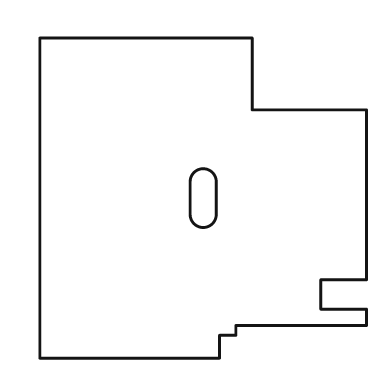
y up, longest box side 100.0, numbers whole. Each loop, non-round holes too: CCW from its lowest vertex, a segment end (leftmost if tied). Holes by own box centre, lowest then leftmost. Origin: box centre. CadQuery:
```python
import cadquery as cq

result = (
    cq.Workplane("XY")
    .moveTo(-50.0, -49.0)
    .lineTo(5.0, -49.0)
    .lineTo(5.0, -42.0)
    .lineTo(10.0, -42.0)
    .lineTo(10.0, -39.0)
    .lineTo(50.0, -39.0)
    .lineTo(50.0, -34.0)
    .lineTo(36.0, -34.0)
    .lineTo(36.0, -25.0)
    .lineTo(50.0, -25.0)
    .lineTo(50.0, 27.0)
    .lineTo(15.0, 27.0)
    .lineTo(15.0, 49.0)
    .lineTo(-50.0, 49.0)
    .close()
    .moveTo(-4.0, -5.0)
    .threePointArc((0.0, -9.0), (4.0, -5.0))
    .lineTo(4.0, 5.0)
    .threePointArc((0.0, 9.0), (-4.0, 5.0))
    .close()
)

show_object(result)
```